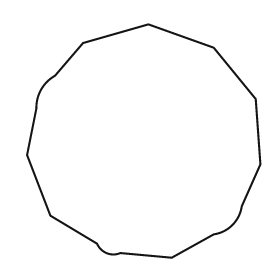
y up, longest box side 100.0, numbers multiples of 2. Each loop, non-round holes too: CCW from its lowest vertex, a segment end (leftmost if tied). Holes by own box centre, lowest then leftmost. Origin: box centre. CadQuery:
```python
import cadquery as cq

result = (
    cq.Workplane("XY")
    .moveTo(12.0, -50.0)
    .lineTo(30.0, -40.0)
    .threePointArc((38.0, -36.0), (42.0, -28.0))
    .lineTo(50.0, -10.0)
    .lineTo(48.0, 18.0)
    .lineTo(30.0, 40.0)
    .lineTo(2.0, 50.0)
    .lineTo(-26.0, 42.0)
    .lineTo(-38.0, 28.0)
    .threePointArc((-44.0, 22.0), (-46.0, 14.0))
    .lineTo(-50.0, -6.0)
    .lineTo(-40.0, -32.0)
    .lineTo(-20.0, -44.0)
    .threePointArc((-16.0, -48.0), (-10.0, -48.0))
    .close()
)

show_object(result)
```